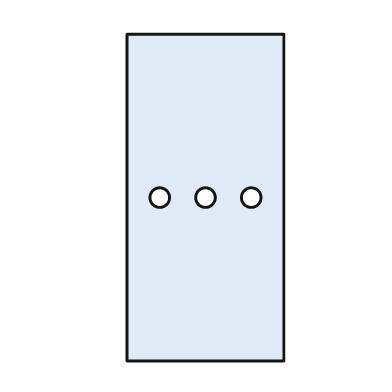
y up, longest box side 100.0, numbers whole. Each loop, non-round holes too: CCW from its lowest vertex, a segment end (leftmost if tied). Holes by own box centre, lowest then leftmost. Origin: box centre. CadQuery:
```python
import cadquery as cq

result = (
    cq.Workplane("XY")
    .moveTo(-24.0, -50.0)
    .lineTo(24.0, -50.0)
    .lineTo(24.0, 50.0)
    .lineTo(-24.0, 50.0)
    .close()
    .moveTo(-14.0, 0.0)
    .circle(3.0)
    .moveTo(0.0, 0.0)
    .circle(3.0)
    .moveTo(14.0, 0.0)
    .circle(3.0)
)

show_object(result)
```